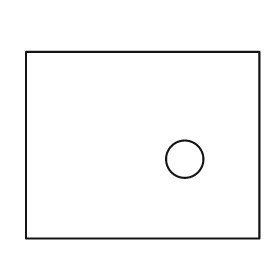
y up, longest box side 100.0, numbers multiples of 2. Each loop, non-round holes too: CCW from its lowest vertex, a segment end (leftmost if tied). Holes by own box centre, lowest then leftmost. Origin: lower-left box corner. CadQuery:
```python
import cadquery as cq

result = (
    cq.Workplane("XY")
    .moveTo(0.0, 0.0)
    .lineTo(100.0, 0.0)
    .lineTo(100.0, 80.0)
    .lineTo(0.0, 80.0)
    .close()
    .moveTo(68.0, 34.0)
    .circle(8.0)
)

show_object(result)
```